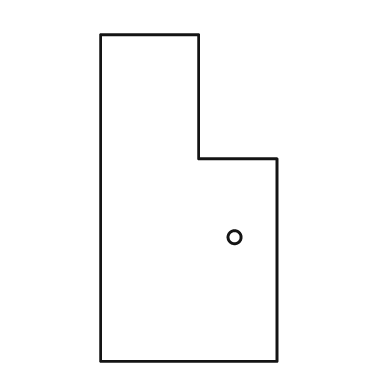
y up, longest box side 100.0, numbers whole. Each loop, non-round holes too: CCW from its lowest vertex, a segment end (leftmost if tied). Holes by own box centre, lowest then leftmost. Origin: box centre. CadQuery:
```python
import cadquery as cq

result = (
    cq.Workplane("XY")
    .moveTo(-27.0, -50.0)
    .lineTo(27.0, -50.0)
    .lineTo(27.0, 12.0)
    .lineTo(3.0, 12.0)
    .lineTo(3.0, 50.0)
    .lineTo(-27.0, 50.0)
    .close()
    .moveTo(14.0, -12.0)
    .circle(2.0)
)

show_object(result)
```